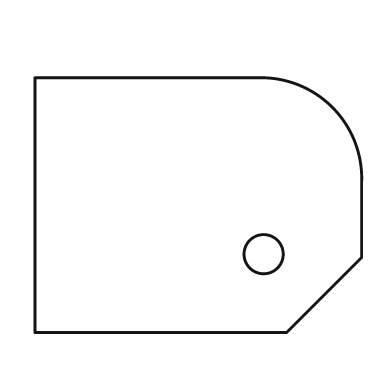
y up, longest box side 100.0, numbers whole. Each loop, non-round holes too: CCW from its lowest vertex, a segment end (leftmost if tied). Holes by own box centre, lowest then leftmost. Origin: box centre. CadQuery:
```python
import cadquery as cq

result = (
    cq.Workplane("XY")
    .moveTo(-50.0, -39.0)
    .lineTo(27.0, -39.0)
    .lineTo(50.0, -16.0)
    .lineTo(50.0, 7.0)
    .threePointArc((41.0, 30.0), (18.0, 39.0))
    .lineTo(-50.0, 39.0)
    .close()
    .moveTo(20.0, -15.0)
    .circle(6.0)
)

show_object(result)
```